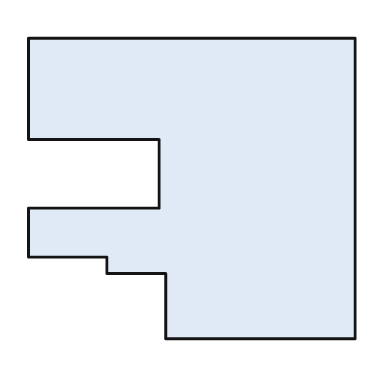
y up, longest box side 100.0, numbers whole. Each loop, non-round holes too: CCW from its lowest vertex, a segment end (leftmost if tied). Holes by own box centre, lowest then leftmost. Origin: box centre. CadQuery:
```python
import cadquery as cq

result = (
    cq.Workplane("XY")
    .moveTo(-8.0, -46.0)
    .lineTo(50.0, -46.0)
    .lineTo(50.0, 46.0)
    .lineTo(-50.0, 46.0)
    .lineTo(-50.0, 15.0)
    .lineTo(-10.0, 15.0)
    .lineTo(-10.0, -6.0)
    .lineTo(-50.0, -6.0)
    .lineTo(-50.0, -21.0)
    .lineTo(-26.0, -21.0)
    .lineTo(-26.0, -26.0)
    .lineTo(-8.0, -26.0)
    .close()
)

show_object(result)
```